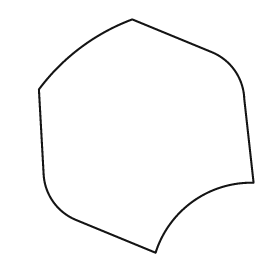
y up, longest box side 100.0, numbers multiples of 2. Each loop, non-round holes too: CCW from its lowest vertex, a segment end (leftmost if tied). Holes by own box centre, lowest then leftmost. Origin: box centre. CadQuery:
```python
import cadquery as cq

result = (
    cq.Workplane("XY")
    .moveTo(4.0, -50.0)
    .threePointArc((20.0, -28.0), (46.0, -20.0))
    .lineTo(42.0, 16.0)
    .threePointArc((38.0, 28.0), (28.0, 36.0))
    .lineTo(-6.0, 50.0)
    .threePointArc((-28.0, 38.0), (-46.0, 20.0))
    .lineTo(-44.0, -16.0)
    .threePointArc((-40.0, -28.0), (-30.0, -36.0))
    .close()
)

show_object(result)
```